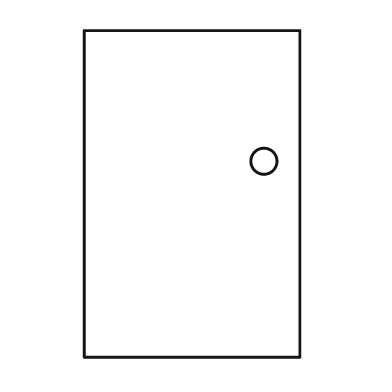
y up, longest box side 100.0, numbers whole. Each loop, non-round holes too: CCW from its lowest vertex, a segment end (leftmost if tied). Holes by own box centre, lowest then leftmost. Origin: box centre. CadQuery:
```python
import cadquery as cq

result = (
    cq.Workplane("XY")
    .moveTo(-33.0, -50.0)
    .lineTo(33.0, -50.0)
    .lineTo(33.0, 50.0)
    .lineTo(-33.0, 50.0)
    .close()
    .moveTo(22.0, 10.0)
    .circle(4.0)
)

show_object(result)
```